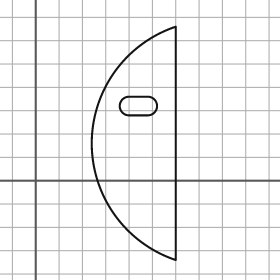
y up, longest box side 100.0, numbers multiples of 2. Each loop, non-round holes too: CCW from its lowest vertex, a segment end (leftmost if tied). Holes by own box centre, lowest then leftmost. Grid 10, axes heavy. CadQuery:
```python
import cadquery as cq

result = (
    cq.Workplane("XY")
    .moveTo(60.0, -34.0)
    .lineTo(60.0, 66.0)
    .threePointArc((24.0, 16.0), (60.0, -34.0))
    .close()
    .moveTo(40.0, 28.0)
    .lineTo(48.0, 28.0)
    .threePointArc((52.0, 32.0), (48.0, 36.0))
    .lineTo(40.0, 36.0)
    .threePointArc((36.0, 32.0), (40.0, 28.0))
    .close()
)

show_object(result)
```